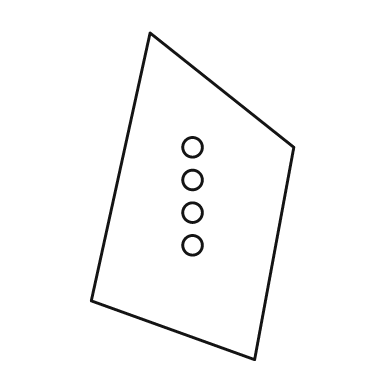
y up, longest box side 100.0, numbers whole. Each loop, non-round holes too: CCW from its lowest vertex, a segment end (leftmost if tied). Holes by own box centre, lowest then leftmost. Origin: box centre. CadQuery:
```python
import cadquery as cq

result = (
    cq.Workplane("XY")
    .moveTo(19.0, -50.0)
    .lineTo(31.0, 15.0)
    .lineTo(-13.0, 50.0)
    .lineTo(-31.0, -32.0)
    .close()
    .moveTo(0.0, -15.0)
    .circle(3.0)
    .moveTo(0.0, -5.0)
    .circle(3.0)
    .moveTo(0.0, 5.0)
    .circle(3.0)
    .moveTo(0.0, 15.0)
    .circle(3.0)
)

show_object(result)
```